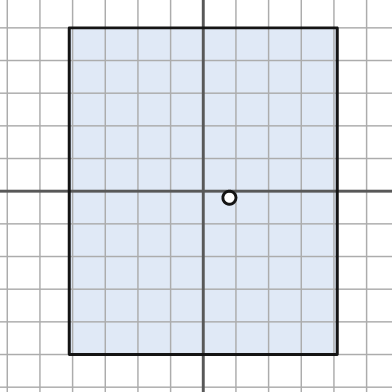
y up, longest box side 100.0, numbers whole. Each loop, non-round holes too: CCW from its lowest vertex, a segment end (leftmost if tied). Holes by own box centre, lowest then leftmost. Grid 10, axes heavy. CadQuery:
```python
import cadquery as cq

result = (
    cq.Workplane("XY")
    .moveTo(-41.0, -50.0)
    .lineTo(41.0, -50.0)
    .lineTo(41.0, 50.0)
    .lineTo(-41.0, 50.0)
    .close()
    .moveTo(8.0, -2.0)
    .circle(2.0)
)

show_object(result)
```